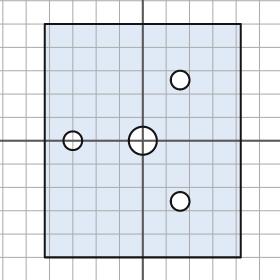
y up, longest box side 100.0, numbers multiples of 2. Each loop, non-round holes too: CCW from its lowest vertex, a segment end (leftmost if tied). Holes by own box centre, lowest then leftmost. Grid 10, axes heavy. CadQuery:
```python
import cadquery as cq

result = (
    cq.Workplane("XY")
    .moveTo(-42.0, -50.0)
    .lineTo(42.0, -50.0)
    .lineTo(42.0, 50.0)
    .lineTo(-42.0, 50.0)
    .close()
    .moveTo(16.0, -26.0)
    .circle(4.0)
    .moveTo(-30.0, 0.0)
    .circle(4.0)
    .moveTo(0.0, 0.0)
    .circle(6.0)
    .moveTo(16.0, 26.0)
    .circle(4.0)
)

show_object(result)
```